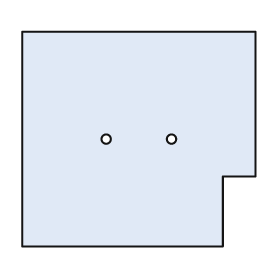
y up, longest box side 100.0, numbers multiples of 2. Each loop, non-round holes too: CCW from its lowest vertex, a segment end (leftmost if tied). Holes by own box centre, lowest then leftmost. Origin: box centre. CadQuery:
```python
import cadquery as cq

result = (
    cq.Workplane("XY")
    .moveTo(-50.0, -46.0)
    .lineTo(36.0, -46.0)
    .lineTo(36.0, -16.0)
    .lineTo(50.0, -16.0)
    .lineTo(50.0, 46.0)
    .lineTo(-50.0, 46.0)
    .close()
    .moveTo(-14.0, 0.0)
    .circle(2.0)
    .moveTo(14.0, 0.0)
    .circle(2.0)
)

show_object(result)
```